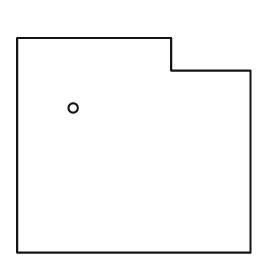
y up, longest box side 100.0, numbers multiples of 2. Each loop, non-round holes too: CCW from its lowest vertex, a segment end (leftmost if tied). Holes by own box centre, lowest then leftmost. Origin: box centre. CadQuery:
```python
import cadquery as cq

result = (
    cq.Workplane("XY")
    .moveTo(-50.0, -46.0)
    .lineTo(50.0, -46.0)
    .lineTo(50.0, 32.0)
    .lineTo(16.0, 32.0)
    .lineTo(16.0, 46.0)
    .lineTo(-50.0, 46.0)
    .close()
    .moveTo(-26.0, 16.0)
    .circle(2.0)
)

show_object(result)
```